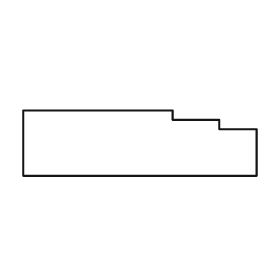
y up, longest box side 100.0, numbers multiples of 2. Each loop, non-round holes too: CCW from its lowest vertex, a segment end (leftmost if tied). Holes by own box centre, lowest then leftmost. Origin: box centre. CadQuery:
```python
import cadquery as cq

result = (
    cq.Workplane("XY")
    .moveTo(-50.0, -14.0)
    .lineTo(50.0, -14.0)
    .lineTo(50.0, 6.0)
    .lineTo(34.0, 6.0)
    .lineTo(34.0, 10.0)
    .lineTo(14.0, 10.0)
    .lineTo(14.0, 14.0)
    .lineTo(-50.0, 14.0)
    .close()
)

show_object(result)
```